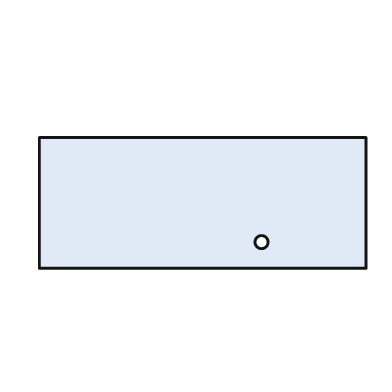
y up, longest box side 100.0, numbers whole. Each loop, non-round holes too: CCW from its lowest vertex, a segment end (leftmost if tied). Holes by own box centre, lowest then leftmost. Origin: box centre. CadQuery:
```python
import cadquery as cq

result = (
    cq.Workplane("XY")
    .moveTo(-50.0, -20.0)
    .lineTo(50.0, -20.0)
    .lineTo(50.0, 20.0)
    .lineTo(-50.0, 20.0)
    .close()
    .moveTo(18.0, -12.0)
    .circle(2.0)
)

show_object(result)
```